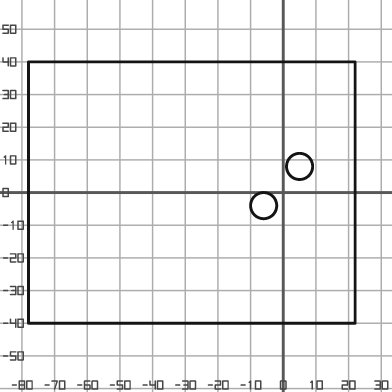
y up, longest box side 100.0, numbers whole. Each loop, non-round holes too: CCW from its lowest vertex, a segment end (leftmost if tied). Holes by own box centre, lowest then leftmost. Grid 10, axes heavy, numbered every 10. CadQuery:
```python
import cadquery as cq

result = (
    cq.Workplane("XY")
    .moveTo(-78.0, -40.0)
    .lineTo(22.0, -40.0)
    .lineTo(22.0, 40.0)
    .lineTo(-78.0, 40.0)
    .close()
    .moveTo(-6.0, -4.0)
    .circle(4.0)
    .moveTo(5.0, 8.0)
    .circle(4.0)
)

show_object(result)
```